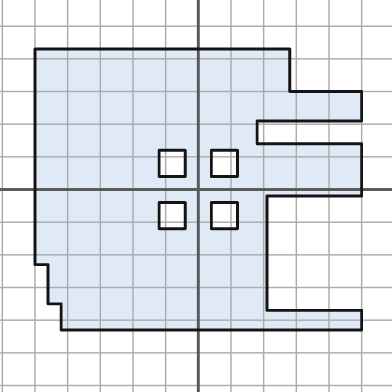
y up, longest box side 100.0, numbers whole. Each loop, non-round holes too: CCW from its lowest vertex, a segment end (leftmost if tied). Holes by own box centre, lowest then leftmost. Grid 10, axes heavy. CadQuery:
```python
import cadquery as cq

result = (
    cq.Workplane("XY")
    .moveTo(-42.0, -43.0)
    .lineTo(50.0, -43.0)
    .lineTo(50.0, -37.0)
    .lineTo(21.0, -37.0)
    .lineTo(21.0, -2.0)
    .lineTo(50.0, -2.0)
    .lineTo(50.0, 14.0)
    .lineTo(18.0, 14.0)
    .lineTo(18.0, 21.0)
    .lineTo(50.0, 21.0)
    .lineTo(50.0, 30.0)
    .lineTo(28.0, 30.0)
    .lineTo(28.0, 43.0)
    .lineTo(-50.0, 43.0)
    .lineTo(-50.0, -23.0)
    .lineTo(-46.0, -23.0)
    .lineTo(-46.0, -35.0)
    .lineTo(-42.0, -35.0)
    .close()
    .moveTo(-12.0, -12.0)
    .lineTo(-4.0, -12.0)
    .lineTo(-4.0, -4.0)
    .lineTo(-12.0, -4.0)
    .close()
    .moveTo(4.0, -12.0)
    .lineTo(12.0, -12.0)
    .lineTo(12.0, -4.0)
    .lineTo(4.0, -4.0)
    .close()
    .moveTo(-12.0, 4.0)
    .lineTo(-4.0, 4.0)
    .lineTo(-4.0, 12.0)
    .lineTo(-12.0, 12.0)
    .close()
    .moveTo(4.0, 4.0)
    .lineTo(12.0, 4.0)
    .lineTo(12.0, 12.0)
    .lineTo(4.0, 12.0)
    .close()
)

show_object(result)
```